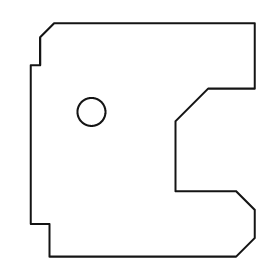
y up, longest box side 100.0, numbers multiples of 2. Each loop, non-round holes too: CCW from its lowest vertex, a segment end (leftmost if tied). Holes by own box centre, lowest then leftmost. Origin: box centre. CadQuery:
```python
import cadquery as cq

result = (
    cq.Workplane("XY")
    .moveTo(-40.0, -50.0)
    .lineTo(40.0, -50.0)
    .lineTo(48.0, -42.0)
    .lineTo(48.0, -30.0)
    .lineTo(40.0, -22.0)
    .lineTo(14.0, -22.0)
    .lineTo(14.0, 8.0)
    .lineTo(28.0, 22.0)
    .lineTo(48.0, 22.0)
    .lineTo(48.0, 50.0)
    .lineTo(-38.0, 50.0)
    .lineTo(-44.0, 44.0)
    .lineTo(-44.0, 32.0)
    .lineTo(-48.0, 32.0)
    .lineTo(-48.0, -36.0)
    .lineTo(-40.0, -36.0)
    .close()
    .moveTo(-22.0, 12.0)
    .circle(6.0)
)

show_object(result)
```